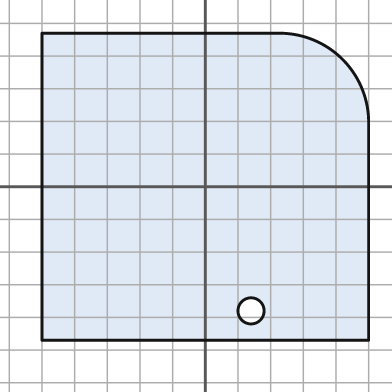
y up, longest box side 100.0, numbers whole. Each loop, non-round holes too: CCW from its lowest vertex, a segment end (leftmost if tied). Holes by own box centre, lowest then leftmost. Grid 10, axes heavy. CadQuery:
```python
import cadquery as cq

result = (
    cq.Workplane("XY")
    .moveTo(-50.0, -47.0)
    .lineTo(50.0, -47.0)
    .lineTo(50.0, 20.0)
    .threePointArc((42.0, 39.0), (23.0, 47.0))
    .lineTo(-50.0, 47.0)
    .close()
    .moveTo(14.0, -38.0)
    .circle(4.0)
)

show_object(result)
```